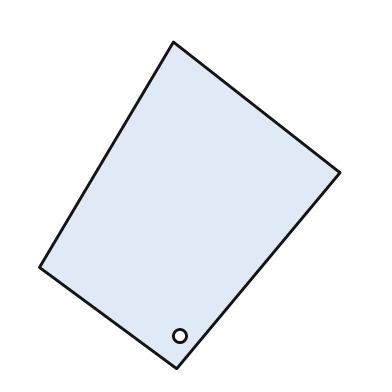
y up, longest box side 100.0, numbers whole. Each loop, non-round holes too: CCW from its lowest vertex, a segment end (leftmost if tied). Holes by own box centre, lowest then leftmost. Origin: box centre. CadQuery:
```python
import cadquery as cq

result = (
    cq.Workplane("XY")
    .moveTo(-4.0, -50.0)
    .lineTo(46.0, 10.0)
    .lineTo(-5.0, 50.0)
    .lineTo(-46.0, -19.0)
    .close()
    .moveTo(-3.0, -40.0)
    .circle(2.0)
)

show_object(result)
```